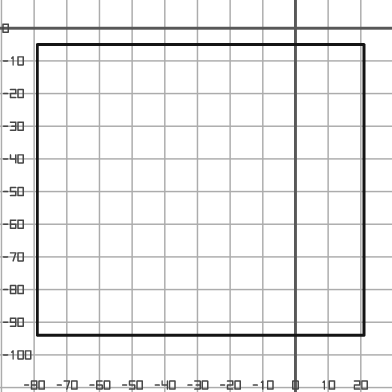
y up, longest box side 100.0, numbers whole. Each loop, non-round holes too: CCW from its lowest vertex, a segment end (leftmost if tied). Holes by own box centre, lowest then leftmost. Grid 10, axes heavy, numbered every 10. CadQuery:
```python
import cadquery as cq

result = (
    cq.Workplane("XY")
    .moveTo(-79.0, -94.0)
    .lineTo(21.0, -94.0)
    .lineTo(21.0, -5.0)
    .lineTo(-79.0, -5.0)
    .close()
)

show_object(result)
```